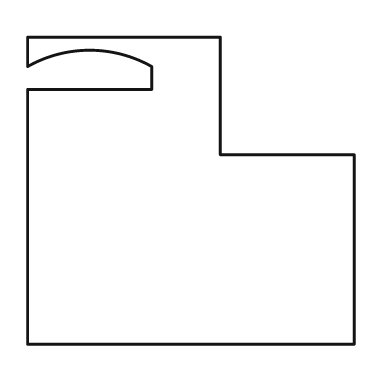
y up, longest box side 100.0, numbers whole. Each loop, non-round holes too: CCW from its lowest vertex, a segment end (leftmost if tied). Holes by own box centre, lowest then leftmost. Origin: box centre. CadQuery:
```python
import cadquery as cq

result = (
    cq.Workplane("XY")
    .moveTo(-50.0, -47.0)
    .lineTo(50.0, -47.0)
    .lineTo(50.0, 11.0)
    .lineTo(9.0, 11.0)
    .lineTo(9.0, 47.0)
    .lineTo(-50.0, 47.0)
    .lineTo(-50.0, 38.0)
    .threePointArc((-31.0, 43.0), (-12.0, 38.0))
    .lineTo(-12.0, 31.0)
    .lineTo(-50.0, 31.0)
    .close()
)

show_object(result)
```